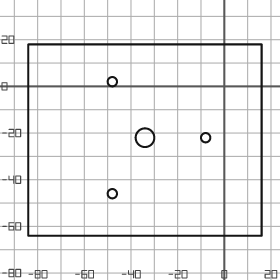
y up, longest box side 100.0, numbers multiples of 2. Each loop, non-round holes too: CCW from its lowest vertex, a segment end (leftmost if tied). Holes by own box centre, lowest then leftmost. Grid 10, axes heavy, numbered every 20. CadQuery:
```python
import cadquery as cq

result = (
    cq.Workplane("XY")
    .moveTo(-84.0, -64.0)
    .lineTo(16.0, -64.0)
    .lineTo(16.0, 18.0)
    .lineTo(-84.0, 18.0)
    .close()
    .moveTo(-48.0, -46.0)
    .circle(2.0)
    .moveTo(-34.0, -22.0)
    .circle(4.0)
    .moveTo(-8.0, -22.0)
    .circle(2.0)
    .moveTo(-48.0, 2.0)
    .circle(2.0)
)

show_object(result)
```